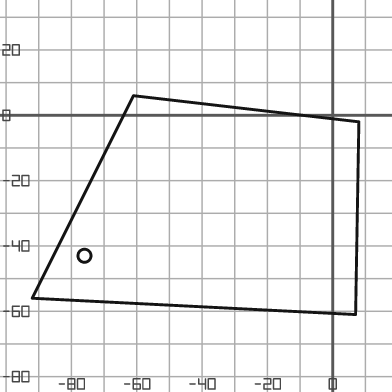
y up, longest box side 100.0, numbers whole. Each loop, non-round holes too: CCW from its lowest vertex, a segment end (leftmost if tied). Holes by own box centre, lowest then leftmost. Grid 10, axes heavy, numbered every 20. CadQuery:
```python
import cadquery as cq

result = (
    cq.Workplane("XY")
    .moveTo(7.0, -61.0)
    .lineTo(8.0, -2.0)
    .lineTo(-61.0, 6.0)
    .lineTo(-92.0, -56.0)
    .close()
    .moveTo(-76.0, -43.0)
    .circle(2.0)
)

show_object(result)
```